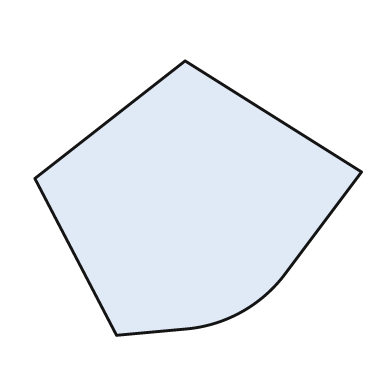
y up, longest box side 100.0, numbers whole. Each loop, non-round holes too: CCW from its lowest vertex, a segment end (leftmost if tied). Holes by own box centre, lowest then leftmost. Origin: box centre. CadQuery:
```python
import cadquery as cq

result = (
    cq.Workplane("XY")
    .moveTo(-25.0, -42.0)
    .lineTo(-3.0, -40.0)
    .threePointArc((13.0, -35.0), (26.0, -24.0))
    .lineTo(50.0, 8.0)
    .lineTo(-4.0, 42.0)
    .lineTo(-50.0, 6.0)
    .close()
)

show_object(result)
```